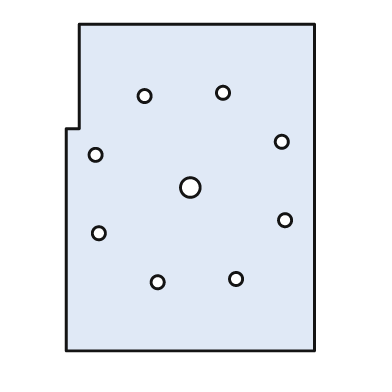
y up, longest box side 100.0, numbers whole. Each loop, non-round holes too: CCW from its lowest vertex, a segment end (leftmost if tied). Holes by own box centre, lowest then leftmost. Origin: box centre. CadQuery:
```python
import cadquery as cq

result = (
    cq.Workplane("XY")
    .moveTo(-38.0, -50.0)
    .lineTo(38.0, -50.0)
    .lineTo(38.0, 50.0)
    .lineTo(-34.0, 50.0)
    .lineTo(-34.0, 18.0)
    .lineTo(-38.0, 18.0)
    .close()
    .moveTo(-10.0, -29.0)
    .circle(2.0)
    .moveTo(14.0, -28.0)
    .circle(2.0)
    .moveTo(-28.0, -14.0)
    .circle(2.0)
    .moveTo(29.0, -10.0)
    .circle(2.0)
    .moveTo(0.0, 0.0)
    .circle(3.0)
    .moveTo(-29.0, 10.0)
    .circle(2.0)
    .moveTo(28.0, 14.0)
    .circle(2.0)
    .moveTo(-14.0, 28.0)
    .circle(2.0)
    .moveTo(10.0, 29.0)
    .circle(2.0)
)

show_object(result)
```